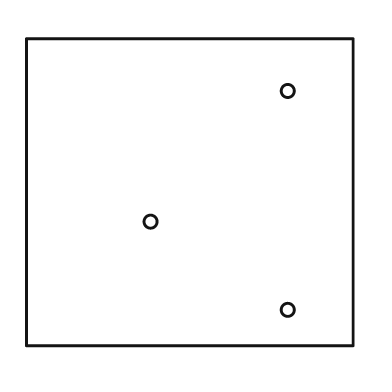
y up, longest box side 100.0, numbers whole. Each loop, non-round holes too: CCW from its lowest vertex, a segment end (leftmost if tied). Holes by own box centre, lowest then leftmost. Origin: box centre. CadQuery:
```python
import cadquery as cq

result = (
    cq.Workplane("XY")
    .moveTo(-50.0, -47.0)
    .lineTo(50.0, -47.0)
    .lineTo(50.0, 47.0)
    .lineTo(-50.0, 47.0)
    .close()
    .moveTo(30.0, -36.0)
    .circle(2.0)
    .moveTo(-12.0, -9.0)
    .circle(2.0)
    .moveTo(30.0, 31.0)
    .circle(2.0)
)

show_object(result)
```